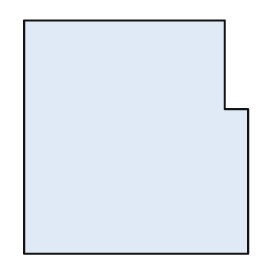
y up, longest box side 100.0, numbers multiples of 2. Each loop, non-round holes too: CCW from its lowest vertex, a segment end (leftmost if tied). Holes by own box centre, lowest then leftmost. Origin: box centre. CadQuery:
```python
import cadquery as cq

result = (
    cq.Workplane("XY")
    .moveTo(-48.0, -50.0)
    .lineTo(48.0, -50.0)
    .lineTo(48.0, 12.0)
    .lineTo(38.0, 12.0)
    .lineTo(38.0, 50.0)
    .lineTo(-48.0, 50.0)
    .close()
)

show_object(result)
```